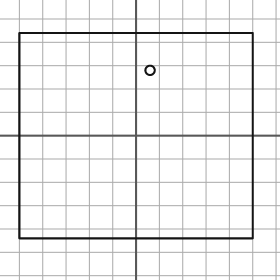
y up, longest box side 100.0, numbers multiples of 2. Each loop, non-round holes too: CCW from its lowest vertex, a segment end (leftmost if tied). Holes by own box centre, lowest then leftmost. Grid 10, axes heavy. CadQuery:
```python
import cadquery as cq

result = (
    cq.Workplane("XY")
    .moveTo(-50.0, -44.0)
    .lineTo(50.0, -44.0)
    .lineTo(50.0, 44.0)
    .lineTo(-50.0, 44.0)
    .close()
    .moveTo(6.0, 28.0)
    .circle(2.0)
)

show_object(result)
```